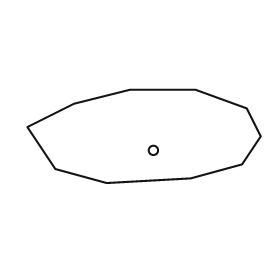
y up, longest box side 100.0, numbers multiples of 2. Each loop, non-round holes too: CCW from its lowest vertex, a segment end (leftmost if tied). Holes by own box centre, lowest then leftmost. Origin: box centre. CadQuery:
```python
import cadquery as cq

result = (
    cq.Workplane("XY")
    .moveTo(-16.0, -20.0)
    .lineTo(20.0, -18.0)
    .lineTo(42.0, -12.0)
    .lineTo(50.0, 0.0)
    .lineTo(44.0, 12.0)
    .lineTo(22.0, 20.0)
    .lineTo(-6.0, 20.0)
    .lineTo(-30.0, 14.0)
    .lineTo(-50.0, 4.0)
    .lineTo(-38.0, -14.0)
    .close()
    .moveTo(4.0, -6.0)
    .circle(2.0)
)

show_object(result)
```